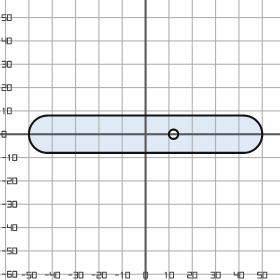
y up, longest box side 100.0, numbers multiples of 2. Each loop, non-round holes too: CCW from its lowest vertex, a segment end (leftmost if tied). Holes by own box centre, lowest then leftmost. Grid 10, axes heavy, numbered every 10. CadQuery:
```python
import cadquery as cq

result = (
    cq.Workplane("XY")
    .moveTo(-42.0, -8.0)
    .lineTo(42.0, -8.0)
    .threePointArc((50.0, 0.0), (42.0, 8.0))
    .lineTo(-42.0, 8.0)
    .threePointArc((-50.0, 0.0), (-42.0, -8.0))
    .close()
    .moveTo(12.0, 0.0)
    .circle(2.0)
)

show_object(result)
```